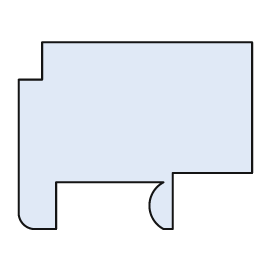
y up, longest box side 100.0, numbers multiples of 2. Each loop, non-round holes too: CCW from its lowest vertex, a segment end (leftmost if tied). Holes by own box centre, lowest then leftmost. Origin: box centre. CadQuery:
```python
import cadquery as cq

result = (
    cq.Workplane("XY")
    .moveTo(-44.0, -40.0)
    .lineTo(-34.0, -40.0)
    .lineTo(-34.0, -20.0)
    .lineTo(12.0, -20.0)
    .threePointArc((6.0, -30.0), (12.0, -40.0))
    .lineTo(16.0, -40.0)
    .lineTo(16.0, -16.0)
    .lineTo(50.0, -16.0)
    .lineTo(50.0, 40.0)
    .lineTo(-40.0, 40.0)
    .lineTo(-40.0, 24.0)
    .lineTo(-50.0, 24.0)
    .lineTo(-50.0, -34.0)
    .threePointArc((-48.0, -38.0), (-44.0, -40.0))
    .close()
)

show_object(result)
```